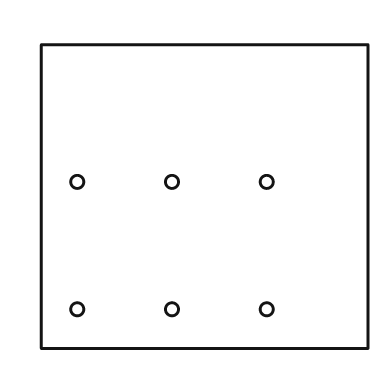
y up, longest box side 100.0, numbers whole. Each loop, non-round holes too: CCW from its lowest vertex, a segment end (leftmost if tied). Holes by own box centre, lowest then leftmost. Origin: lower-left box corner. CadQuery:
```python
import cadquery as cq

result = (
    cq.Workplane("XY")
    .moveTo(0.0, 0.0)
    .lineTo(100.0, 0.0)
    .lineTo(100.0, 93.0)
    .lineTo(0.0, 93.0)
    .close()
    .moveTo(11.0, 12.0)
    .circle(2.0)
    .moveTo(40.0, 12.0)
    .circle(2.0)
    .moveTo(69.0, 12.0)
    .circle(2.0)
    .moveTo(11.0, 51.0)
    .circle(2.0)
    .moveTo(40.0, 51.0)
    .circle(2.0)
    .moveTo(69.0, 51.0)
    .circle(2.0)
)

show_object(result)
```